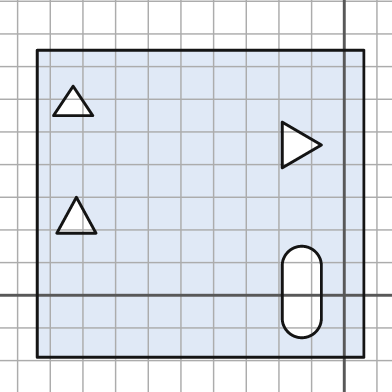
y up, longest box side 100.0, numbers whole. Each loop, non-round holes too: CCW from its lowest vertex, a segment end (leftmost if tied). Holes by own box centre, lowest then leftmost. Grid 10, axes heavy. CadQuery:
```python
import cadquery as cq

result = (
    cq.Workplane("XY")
    .moveTo(-94.0, -19.0)
    .lineTo(6.0, -19.0)
    .lineTo(6.0, 75.0)
    .lineTo(-94.0, 75.0)
    .close()
    .moveTo(-19.0, -7.0)
    .threePointArc((-13.0, -13.0), (-7.0, -7.0))
    .lineTo(-7.0, 9.0)
    .threePointArc((-13.0, 15.0), (-19.0, 9.0))
    .close()
    .moveTo(-88.0, 19.0)
    .lineTo(-76.0, 19.0)
    .lineTo(-82.0, 30.0)
    .close()
    .moveTo(-19.0, 39.0)
    .lineTo(-7.0, 46.0)
    .lineTo(-19.0, 53.0)
    .close()
    .moveTo(-89.0, 55.0)
    .lineTo(-77.0, 55.0)
    .lineTo(-83.0, 64.0)
    .close()
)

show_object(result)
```